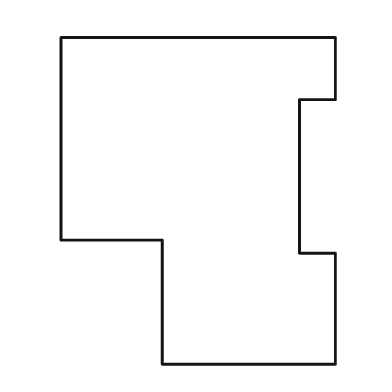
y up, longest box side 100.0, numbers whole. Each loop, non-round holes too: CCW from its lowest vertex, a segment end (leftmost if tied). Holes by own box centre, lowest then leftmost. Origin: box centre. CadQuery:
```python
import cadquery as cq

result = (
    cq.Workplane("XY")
    .moveTo(-11.0, -50.0)
    .lineTo(42.0, -50.0)
    .lineTo(42.0, -16.0)
    .lineTo(31.0, -16.0)
    .lineTo(31.0, 31.0)
    .lineTo(42.0, 31.0)
    .lineTo(42.0, 50.0)
    .lineTo(-42.0, 50.0)
    .lineTo(-42.0, -12.0)
    .lineTo(-11.0, -12.0)
    .close()
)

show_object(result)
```